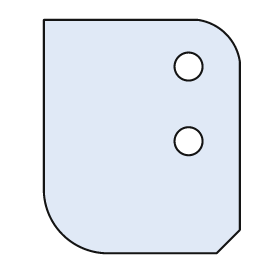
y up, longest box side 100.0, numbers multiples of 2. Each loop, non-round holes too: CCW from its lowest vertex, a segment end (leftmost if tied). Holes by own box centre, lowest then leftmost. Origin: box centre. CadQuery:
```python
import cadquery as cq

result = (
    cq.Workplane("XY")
    .moveTo(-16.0, -50.0)
    .lineTo(32.0, -50.0)
    .lineTo(42.0, -40.0)
    .lineTo(42.0, 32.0)
    .threePointArc((36.0, 44.0), (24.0, 50.0))
    .lineTo(-42.0, 50.0)
    .lineTo(-42.0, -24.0)
    .threePointArc((-34.0, -42.0), (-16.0, -50.0))
    .close()
    .moveTo(20.0, -2.0)
    .circle(6.0)
    .moveTo(20.0, 30.0)
    .circle(6.0)
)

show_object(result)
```